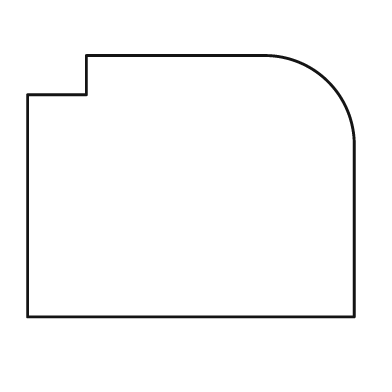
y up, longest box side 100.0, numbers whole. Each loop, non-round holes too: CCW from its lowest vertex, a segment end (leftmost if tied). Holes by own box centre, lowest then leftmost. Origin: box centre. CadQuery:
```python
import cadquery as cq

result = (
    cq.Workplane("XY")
    .moveTo(-50.0, -40.0)
    .lineTo(50.0, -40.0)
    .lineTo(50.0, 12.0)
    .threePointArc((42.0, 32.0), (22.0, 40.0))
    .lineTo(-32.0, 40.0)
    .lineTo(-32.0, 28.0)
    .lineTo(-50.0, 28.0)
    .close()
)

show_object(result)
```